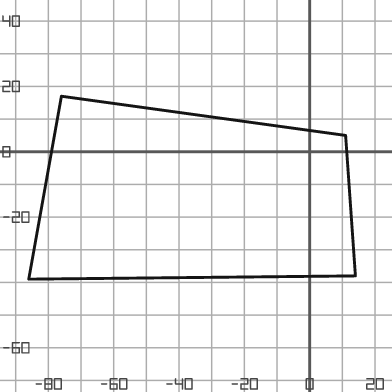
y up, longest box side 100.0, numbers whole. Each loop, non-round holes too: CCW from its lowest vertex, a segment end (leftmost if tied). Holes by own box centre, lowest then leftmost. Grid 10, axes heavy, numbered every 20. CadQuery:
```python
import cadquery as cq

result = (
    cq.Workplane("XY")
    .moveTo(-86.0, -39.0)
    .lineTo(14.0, -38.0)
    .lineTo(11.0, 5.0)
    .lineTo(-76.0, 17.0)
    .close()
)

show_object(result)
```